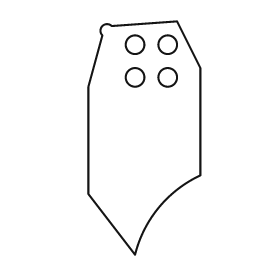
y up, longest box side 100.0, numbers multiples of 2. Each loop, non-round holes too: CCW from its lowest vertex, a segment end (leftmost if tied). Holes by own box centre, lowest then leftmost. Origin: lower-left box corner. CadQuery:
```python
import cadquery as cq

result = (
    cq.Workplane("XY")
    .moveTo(20.0, 0.0)
    .threePointArc((30.0, 20.0), (48.0, 34.0))
    .lineTo(48.0, 80.0)
    .lineTo(38.0, 100.0)
    .lineTo(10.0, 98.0)
    .threePointArc((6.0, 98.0), (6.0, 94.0))
    .lineTo(0.0, 72.0)
    .lineTo(0.0, 26.0)
    .close()
    .moveTo(20.0, 76.0)
    .circle(4.0)
    .moveTo(34.0, 76.0)
    .circle(4.0)
    .moveTo(20.0, 90.0)
    .circle(4.0)
    .moveTo(34.0, 90.0)
    .circle(4.0)
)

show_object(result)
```